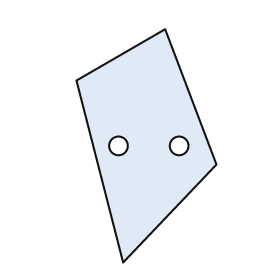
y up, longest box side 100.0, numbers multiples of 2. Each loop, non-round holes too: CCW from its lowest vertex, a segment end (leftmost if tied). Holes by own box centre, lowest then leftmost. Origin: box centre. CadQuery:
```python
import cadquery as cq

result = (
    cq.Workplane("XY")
    .moveTo(-10.0, -50.0)
    .lineTo(30.0, -8.0)
    .lineTo(8.0, 50.0)
    .lineTo(-30.0, 28.0)
    .close()
    .moveTo(-12.0, 0.0)
    .circle(4.0)
    .moveTo(14.0, 0.0)
    .circle(4.0)
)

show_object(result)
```